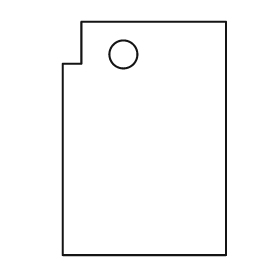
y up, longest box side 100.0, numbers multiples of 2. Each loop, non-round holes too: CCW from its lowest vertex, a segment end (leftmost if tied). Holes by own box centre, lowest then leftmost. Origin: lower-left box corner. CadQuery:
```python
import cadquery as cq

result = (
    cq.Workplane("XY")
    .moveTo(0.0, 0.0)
    .lineTo(70.0, 0.0)
    .lineTo(70.0, 100.0)
    .lineTo(8.0, 100.0)
    .lineTo(8.0, 82.0)
    .lineTo(0.0, 82.0)
    .close()
    .moveTo(26.0, 86.0)
    .circle(6.0)
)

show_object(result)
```